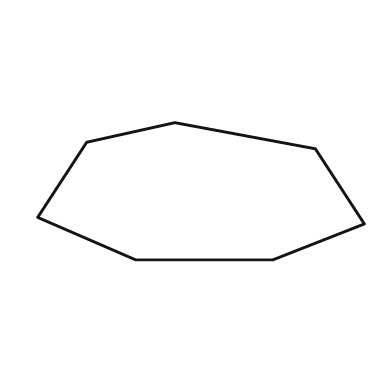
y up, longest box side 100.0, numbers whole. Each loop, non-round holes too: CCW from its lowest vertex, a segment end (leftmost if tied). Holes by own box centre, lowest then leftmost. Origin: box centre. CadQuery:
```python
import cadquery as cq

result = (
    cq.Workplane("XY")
    .moveTo(-20.0, -21.0)
    .lineTo(22.0, -21.0)
    .lineTo(50.0, -10.0)
    .lineTo(35.0, 13.0)
    .lineTo(-8.0, 21.0)
    .lineTo(-35.0, 15.0)
    .lineTo(-50.0, -8.0)
    .close()
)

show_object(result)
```